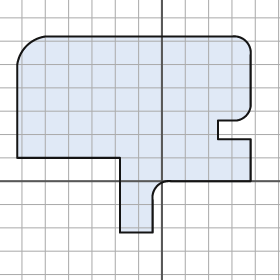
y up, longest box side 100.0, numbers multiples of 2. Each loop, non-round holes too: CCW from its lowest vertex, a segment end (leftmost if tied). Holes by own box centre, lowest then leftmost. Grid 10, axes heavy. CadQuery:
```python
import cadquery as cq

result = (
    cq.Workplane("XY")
    .moveTo(-18.0, -22.0)
    .lineTo(-4.0, -22.0)
    .lineTo(-4.0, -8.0)
    .threePointArc((-2.0, -2.0), (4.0, 0.0))
    .lineTo(38.0, 0.0)
    .lineTo(38.0, 18.0)
    .lineTo(24.0, 18.0)
    .lineTo(24.0, 26.0)
    .lineTo(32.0, 26.0)
    .threePointArc((36.0, 28.0), (38.0, 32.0))
    .lineTo(38.0, 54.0)
    .threePointArc((36.0, 60.0), (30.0, 62.0))
    .lineTo(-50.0, 62.0)
    .threePointArc((-58.0, 58.0), (-62.0, 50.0))
    .lineTo(-62.0, 10.0)
    .lineTo(-18.0, 10.0)
    .close()
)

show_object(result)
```